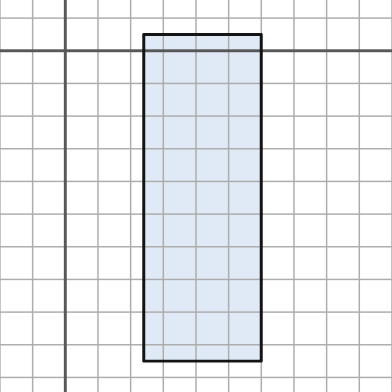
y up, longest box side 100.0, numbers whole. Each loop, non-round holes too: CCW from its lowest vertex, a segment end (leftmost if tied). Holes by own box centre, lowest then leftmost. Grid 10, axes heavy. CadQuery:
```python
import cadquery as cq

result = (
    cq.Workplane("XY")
    .moveTo(24.0, -95.0)
    .lineTo(60.0, -95.0)
    .lineTo(60.0, 5.0)
    .lineTo(24.0, 5.0)
    .close()
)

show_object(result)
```